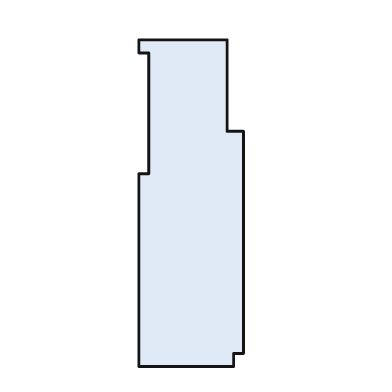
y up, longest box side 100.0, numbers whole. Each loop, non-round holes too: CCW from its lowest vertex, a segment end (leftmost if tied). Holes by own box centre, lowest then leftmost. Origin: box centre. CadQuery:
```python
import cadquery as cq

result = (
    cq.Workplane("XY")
    .moveTo(-16.0, -50.0)
    .lineTo(13.0, -50.0)
    .lineTo(13.0, -46.0)
    .lineTo(16.0, -46.0)
    .lineTo(16.0, 22.0)
    .lineTo(11.0, 22.0)
    .lineTo(11.0, 50.0)
    .lineTo(-16.0, 50.0)
    .lineTo(-16.0, 46.0)
    .lineTo(-13.0, 46.0)
    .lineTo(-13.0, 9.0)
    .lineTo(-16.0, 9.0)
    .close()
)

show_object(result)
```